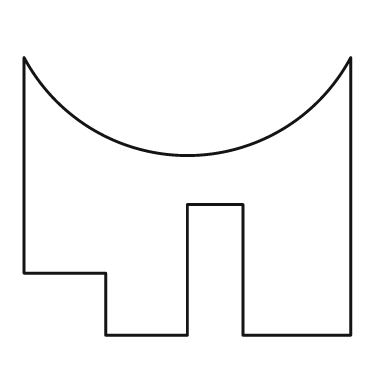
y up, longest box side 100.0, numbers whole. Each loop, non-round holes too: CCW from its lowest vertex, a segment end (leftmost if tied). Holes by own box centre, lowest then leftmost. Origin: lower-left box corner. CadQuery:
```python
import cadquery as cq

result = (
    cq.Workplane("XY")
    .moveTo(25.0, 0.0)
    .lineTo(50.0, 0.0)
    .lineTo(50.0, 40.0)
    .lineTo(67.0, 40.0)
    .lineTo(67.0, 0.0)
    .lineTo(100.0, 0.0)
    .lineTo(100.0, 85.0)
    .threePointArc((50.0, 55.0), (0.0, 85.0))
    .lineTo(0.0, 19.0)
    .lineTo(25.0, 19.0)
    .close()
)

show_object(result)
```